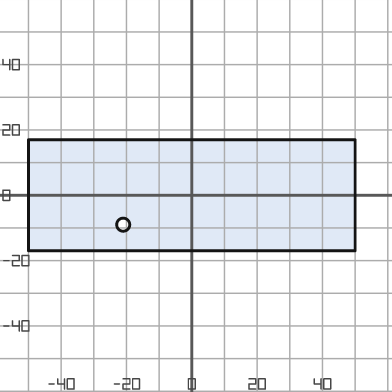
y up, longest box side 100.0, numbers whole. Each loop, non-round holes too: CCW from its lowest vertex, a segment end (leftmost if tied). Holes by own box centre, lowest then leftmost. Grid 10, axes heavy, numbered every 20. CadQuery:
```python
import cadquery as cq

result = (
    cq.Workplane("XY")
    .moveTo(-50.0, -17.0)
    .lineTo(50.0, -17.0)
    .lineTo(50.0, 17.0)
    .lineTo(-50.0, 17.0)
    .close()
    .moveTo(-21.0, -9.0)
    .circle(2.0)
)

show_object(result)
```